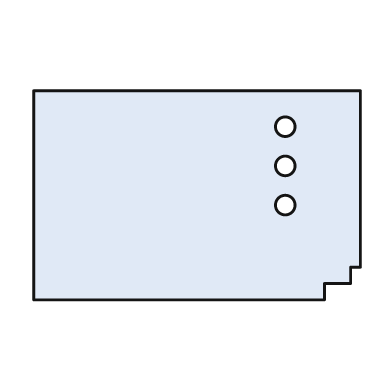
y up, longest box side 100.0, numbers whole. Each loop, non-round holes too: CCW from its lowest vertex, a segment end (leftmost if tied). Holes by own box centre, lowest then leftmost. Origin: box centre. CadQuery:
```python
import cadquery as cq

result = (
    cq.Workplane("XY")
    .moveTo(-50.0, -32.0)
    .lineTo(39.0, -32.0)
    .lineTo(39.0, -27.0)
    .lineTo(47.0, -27.0)
    .lineTo(47.0, -22.0)
    .lineTo(50.0, -22.0)
    .lineTo(50.0, 32.0)
    .lineTo(-50.0, 32.0)
    .close()
    .moveTo(27.0, -3.0)
    .circle(3.0)
    .moveTo(27.0, 9.0)
    .circle(3.0)
    .moveTo(27.0, 21.0)
    .circle(3.0)
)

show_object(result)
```